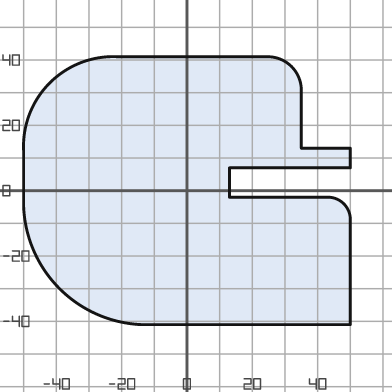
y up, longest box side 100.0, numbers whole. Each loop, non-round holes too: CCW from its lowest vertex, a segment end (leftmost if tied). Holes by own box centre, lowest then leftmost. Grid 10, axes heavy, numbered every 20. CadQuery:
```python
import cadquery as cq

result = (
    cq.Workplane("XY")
    .moveTo(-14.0, -41.0)
    .lineTo(50.0, -41.0)
    .lineTo(50.0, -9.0)
    .threePointArc((48.0, -4.0), (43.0, -2.0))
    .lineTo(13.0, -2.0)
    .lineTo(13.0, 7.0)
    .lineTo(50.0, 7.0)
    .lineTo(50.0, 13.0)
    .lineTo(35.0, 13.0)
    .lineTo(35.0, 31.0)
    .threePointArc((32.0, 38.0), (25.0, 41.0))
    .lineTo(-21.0, 41.0)
    .threePointArc((-42.0, 33.0), (-50.0, 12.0))
    .lineTo(-50.0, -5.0)
    .threePointArc((-39.0, -30.0), (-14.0, -41.0))
    .close()
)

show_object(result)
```